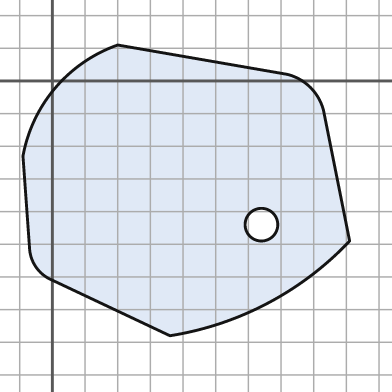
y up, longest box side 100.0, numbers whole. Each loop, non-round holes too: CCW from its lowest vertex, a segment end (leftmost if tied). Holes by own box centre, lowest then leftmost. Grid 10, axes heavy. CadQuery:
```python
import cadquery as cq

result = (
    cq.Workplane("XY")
    .moveTo(36.0, -78.0)
    .threePointArc((66.0, -68.0), (91.0, -49.0))
    .lineTo(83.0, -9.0)
    .threePointArc((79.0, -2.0), (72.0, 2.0))
    .lineTo(20.0, 11.0)
    .threePointArc((1.0, -2.0), (-9.0, -23.0))
    .lineTo(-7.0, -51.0)
    .threePointArc((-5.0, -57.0), (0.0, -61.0))
    .close()
    .moveTo(64.0, -44.0)
    .circle(5.0)
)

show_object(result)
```